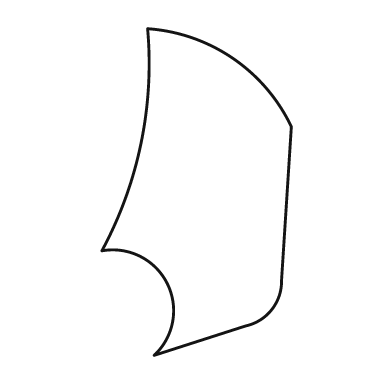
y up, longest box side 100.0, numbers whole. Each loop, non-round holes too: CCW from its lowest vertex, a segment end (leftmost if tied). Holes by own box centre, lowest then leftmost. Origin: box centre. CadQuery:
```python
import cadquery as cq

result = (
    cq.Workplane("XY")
    .moveTo(-13.0, -50.0)
    .lineTo(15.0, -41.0)
    .threePointArc((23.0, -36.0), (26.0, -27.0))
    .lineTo(29.0, 20.0)
    .threePointArc((11.0, 41.0), (-15.0, 50.0))
    .threePointArc((-17.0, 15.0), (-29.0, -18.0))
    .threePointArc((-9.0, -28.0), (-13.0, -50.0))
    .close()
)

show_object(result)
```